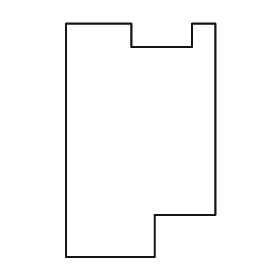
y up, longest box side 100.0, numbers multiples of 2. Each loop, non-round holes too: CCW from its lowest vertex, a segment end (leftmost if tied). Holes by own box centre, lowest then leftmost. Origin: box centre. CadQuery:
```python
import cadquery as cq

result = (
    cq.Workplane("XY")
    .moveTo(-32.0, -50.0)
    .lineTo(6.0, -50.0)
    .lineTo(6.0, -32.0)
    .lineTo(32.0, -32.0)
    .lineTo(32.0, 50.0)
    .lineTo(22.0, 50.0)
    .lineTo(22.0, 40.0)
    .lineTo(-4.0, 40.0)
    .lineTo(-4.0, 50.0)
    .lineTo(-32.0, 50.0)
    .close()
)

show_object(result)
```